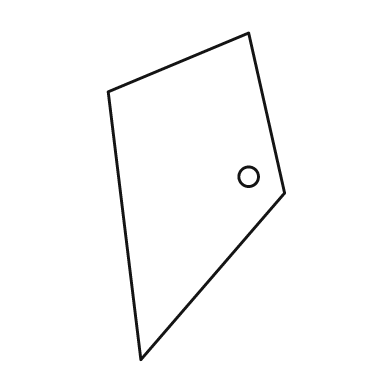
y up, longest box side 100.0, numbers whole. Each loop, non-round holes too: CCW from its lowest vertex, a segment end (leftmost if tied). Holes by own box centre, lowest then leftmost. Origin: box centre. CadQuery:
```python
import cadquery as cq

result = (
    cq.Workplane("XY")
    .moveTo(-17.0, -50.0)
    .lineTo(27.0, 1.0)
    .lineTo(16.0, 50.0)
    .lineTo(-27.0, 32.0)
    .close()
    .moveTo(16.0, 6.0)
    .circle(3.0)
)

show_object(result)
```